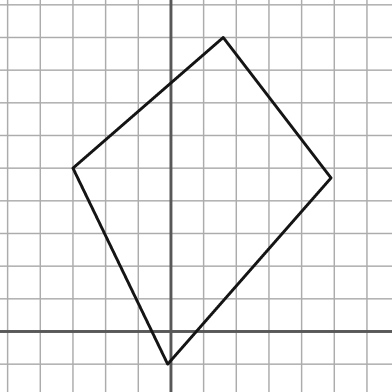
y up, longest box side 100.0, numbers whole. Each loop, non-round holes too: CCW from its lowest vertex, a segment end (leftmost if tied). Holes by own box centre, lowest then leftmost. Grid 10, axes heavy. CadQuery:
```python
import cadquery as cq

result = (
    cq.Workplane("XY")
    .moveTo(-1.0, -10.0)
    .lineTo(49.0, 47.0)
    .lineTo(16.0, 90.0)
    .lineTo(-30.0, 50.0)
    .close()
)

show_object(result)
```